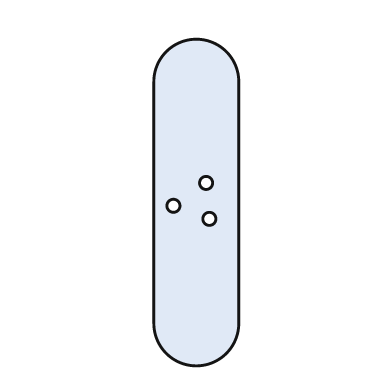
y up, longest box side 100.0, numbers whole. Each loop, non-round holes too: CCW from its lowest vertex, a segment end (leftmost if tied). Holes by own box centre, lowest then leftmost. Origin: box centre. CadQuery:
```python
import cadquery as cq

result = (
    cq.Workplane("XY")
    .moveTo(-13.0, -37.0)
    .threePointArc((0.0, -50.0), (13.0, -37.0))
    .lineTo(13.0, 37.0)
    .threePointArc((0.0, 50.0), (-13.0, 37.0))
    .close()
    .moveTo(4.0, -5.0)
    .circle(2.0)
    .moveTo(-7.0, -1.0)
    .circle(2.0)
    .moveTo(3.0, 6.0)
    .circle(2.0)
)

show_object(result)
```